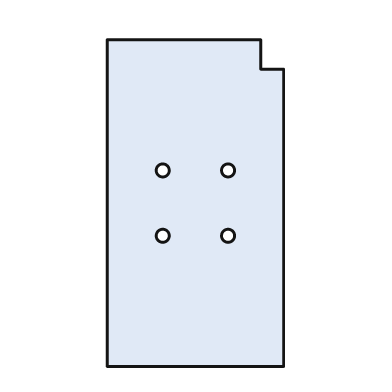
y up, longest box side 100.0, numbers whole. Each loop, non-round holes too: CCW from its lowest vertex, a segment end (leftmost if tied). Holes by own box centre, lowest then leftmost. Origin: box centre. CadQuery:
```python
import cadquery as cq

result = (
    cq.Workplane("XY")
    .moveTo(-27.0, -50.0)
    .lineTo(27.0, -50.0)
    .lineTo(27.0, 41.0)
    .lineTo(20.0, 41.0)
    .lineTo(20.0, 50.0)
    .lineTo(-27.0, 50.0)
    .close()
    .moveTo(-10.0, -10.0)
    .circle(2.0)
    .moveTo(10.0, -10.0)
    .circle(2.0)
    .moveTo(-10.0, 10.0)
    .circle(2.0)
    .moveTo(10.0, 10.0)
    .circle(2.0)
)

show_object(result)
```